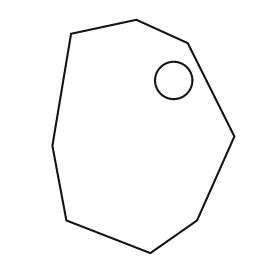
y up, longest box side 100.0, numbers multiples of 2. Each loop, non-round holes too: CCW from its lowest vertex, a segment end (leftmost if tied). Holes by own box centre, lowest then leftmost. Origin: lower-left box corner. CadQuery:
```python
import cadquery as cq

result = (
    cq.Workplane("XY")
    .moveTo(42.0, 0.0)
    .lineTo(62.0, 14.0)
    .lineTo(78.0, 50.0)
    .lineTo(58.0, 90.0)
    .lineTo(36.0, 100.0)
    .lineTo(8.0, 94.0)
    .lineTo(0.0, 46.0)
    .lineTo(6.0, 14.0)
    .close()
    .moveTo(52.0, 74.0)
    .circle(8.0)
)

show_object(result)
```